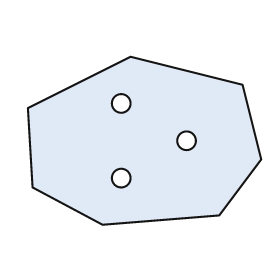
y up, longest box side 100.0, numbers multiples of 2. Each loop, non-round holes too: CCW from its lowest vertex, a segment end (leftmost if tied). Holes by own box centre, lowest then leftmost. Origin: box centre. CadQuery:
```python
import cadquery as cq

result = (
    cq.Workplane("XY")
    .moveTo(-18.0, -36.0)
    .lineTo(32.0, -32.0)
    .lineTo(50.0, -8.0)
    .lineTo(42.0, 24.0)
    .lineTo(-6.0, 36.0)
    .lineTo(-50.0, 14.0)
    .lineTo(-48.0, -20.0)
    .close()
    .moveTo(-10.0, -16.0)
    .circle(4.0)
    .moveTo(18.0, 0.0)
    .circle(4.0)
    .moveTo(-10.0, 16.0)
    .circle(4.0)
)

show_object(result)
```